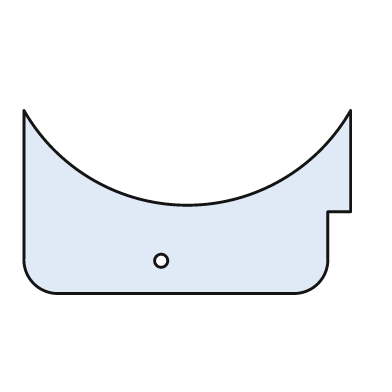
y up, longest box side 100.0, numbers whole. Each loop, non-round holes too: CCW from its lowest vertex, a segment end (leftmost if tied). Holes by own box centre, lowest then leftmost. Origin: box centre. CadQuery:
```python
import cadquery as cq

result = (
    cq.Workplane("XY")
    .moveTo(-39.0, -28.0)
    .lineTo(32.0, -28.0)
    .threePointArc((40.0, -25.0), (43.0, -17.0))
    .lineTo(43.0, -3.0)
    .lineTo(50.0, -3.0)
    .lineTo(50.0, 28.0)
    .threePointArc((0.0, -1.0), (-50.0, 28.0))
    .lineTo(-50.0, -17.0)
    .threePointArc((-47.0, -25.0), (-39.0, -28.0))
    .close()
    .moveTo(-8.0, -18.0)
    .circle(2.0)
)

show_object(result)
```